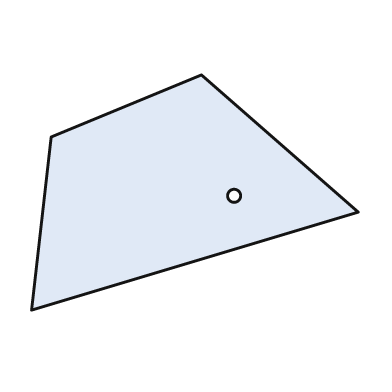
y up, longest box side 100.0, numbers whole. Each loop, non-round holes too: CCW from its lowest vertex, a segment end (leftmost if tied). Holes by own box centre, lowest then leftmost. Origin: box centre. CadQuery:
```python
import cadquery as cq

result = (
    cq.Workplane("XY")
    .moveTo(-50.0, -36.0)
    .lineTo(50.0, -6.0)
    .lineTo(2.0, 36.0)
    .lineTo(-44.0, 17.0)
    .close()
    .moveTo(12.0, -1.0)
    .circle(2.0)
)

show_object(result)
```